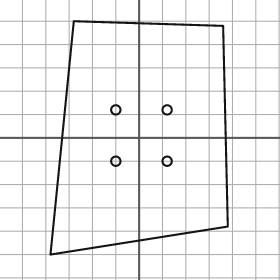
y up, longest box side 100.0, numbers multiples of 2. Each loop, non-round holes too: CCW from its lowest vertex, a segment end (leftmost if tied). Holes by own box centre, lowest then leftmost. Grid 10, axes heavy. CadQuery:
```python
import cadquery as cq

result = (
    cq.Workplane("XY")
    .moveTo(-38.0, -50.0)
    .lineTo(38.0, -38.0)
    .lineTo(36.0, 48.0)
    .lineTo(-28.0, 50.0)
    .close()
    .moveTo(-10.0, -10.0)
    .circle(2.0)
    .moveTo(12.0, -10.0)
    .circle(2.0)
    .moveTo(-10.0, 12.0)
    .circle(2.0)
    .moveTo(12.0, 12.0)
    .circle(2.0)
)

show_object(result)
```